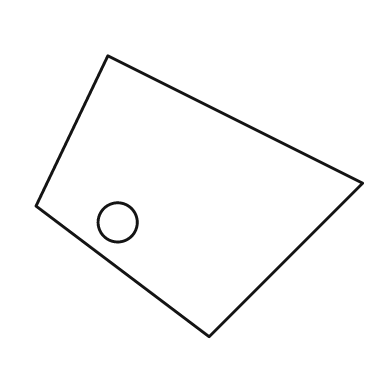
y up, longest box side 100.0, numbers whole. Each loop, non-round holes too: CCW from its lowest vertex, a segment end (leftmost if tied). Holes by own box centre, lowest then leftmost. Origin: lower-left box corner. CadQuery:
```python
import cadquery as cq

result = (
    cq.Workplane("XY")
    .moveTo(53.0, 0.0)
    .lineTo(100.0, 47.0)
    .lineTo(22.0, 86.0)
    .lineTo(0.0, 40.0)
    .close()
    .moveTo(25.0, 35.0)
    .circle(6.0)
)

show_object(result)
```